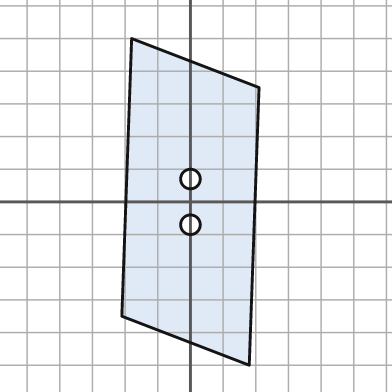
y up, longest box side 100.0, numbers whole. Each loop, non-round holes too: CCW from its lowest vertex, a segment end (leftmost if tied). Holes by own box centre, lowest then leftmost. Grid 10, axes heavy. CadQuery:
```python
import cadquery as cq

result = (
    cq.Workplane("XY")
    .moveTo(18.0, -50.0)
    .lineTo(21.0, 35.0)
    .lineTo(-18.0, 50.0)
    .lineTo(-21.0, -35.0)
    .close()
    .moveTo(0.0, -7.0)
    .circle(3.0)
    .moveTo(0.0, 7.0)
    .circle(3.0)
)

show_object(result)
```